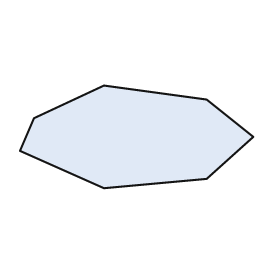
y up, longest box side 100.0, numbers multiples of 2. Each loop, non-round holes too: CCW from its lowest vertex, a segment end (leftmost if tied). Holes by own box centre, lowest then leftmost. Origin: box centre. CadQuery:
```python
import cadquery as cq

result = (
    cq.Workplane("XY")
    .moveTo(-14.0, -22.0)
    .lineTo(30.0, -18.0)
    .lineTo(50.0, 0.0)
    .lineTo(30.0, 16.0)
    .lineTo(-14.0, 22.0)
    .lineTo(-44.0, 8.0)
    .lineTo(-50.0, -6.0)
    .close()
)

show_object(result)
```